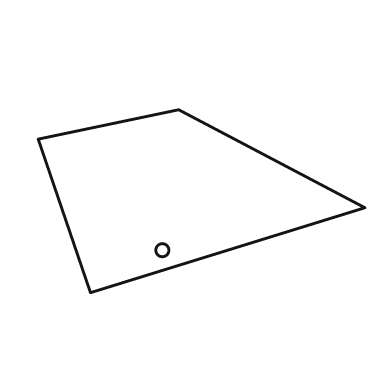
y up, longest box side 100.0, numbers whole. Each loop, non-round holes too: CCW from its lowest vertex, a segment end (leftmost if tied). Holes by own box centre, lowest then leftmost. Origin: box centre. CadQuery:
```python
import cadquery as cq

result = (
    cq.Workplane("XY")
    .moveTo(-34.0, -28.0)
    .lineTo(50.0, -2.0)
    .lineTo(-7.0, 28.0)
    .lineTo(-50.0, 19.0)
    .close()
    .moveTo(-12.0, -15.0)
    .circle(2.0)
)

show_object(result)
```